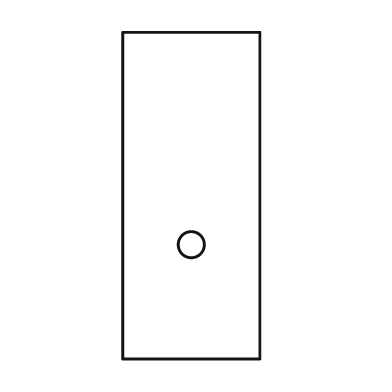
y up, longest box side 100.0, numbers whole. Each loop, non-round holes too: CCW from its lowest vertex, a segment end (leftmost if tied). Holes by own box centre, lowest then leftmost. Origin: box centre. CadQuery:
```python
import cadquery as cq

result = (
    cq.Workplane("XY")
    .moveTo(-21.0, -50.0)
    .lineTo(21.0, -50.0)
    .lineTo(21.0, 50.0)
    .lineTo(-21.0, 50.0)
    .close()
    .moveTo(0.0, -15.0)
    .circle(4.0)
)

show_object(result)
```